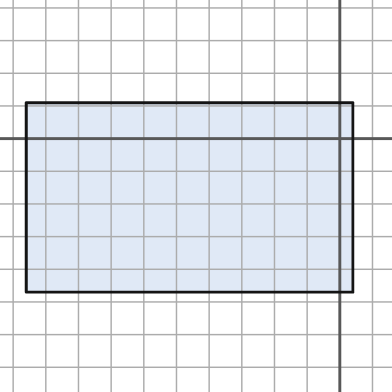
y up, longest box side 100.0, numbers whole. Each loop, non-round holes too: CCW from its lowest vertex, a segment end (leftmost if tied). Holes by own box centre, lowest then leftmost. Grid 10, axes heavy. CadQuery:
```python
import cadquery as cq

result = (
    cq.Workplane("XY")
    .moveTo(-96.0, -47.0)
    .lineTo(4.0, -47.0)
    .lineTo(4.0, 11.0)
    .lineTo(-96.0, 11.0)
    .close()
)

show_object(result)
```